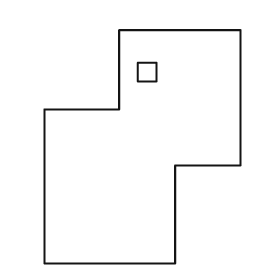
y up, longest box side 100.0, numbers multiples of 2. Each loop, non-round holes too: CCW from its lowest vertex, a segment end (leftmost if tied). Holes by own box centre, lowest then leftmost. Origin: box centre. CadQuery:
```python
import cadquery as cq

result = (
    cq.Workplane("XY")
    .moveTo(-42.0, -50.0)
    .lineTo(14.0, -50.0)
    .lineTo(14.0, -8.0)
    .lineTo(42.0, -8.0)
    .lineTo(42.0, 50.0)
    .lineTo(-10.0, 50.0)
    .lineTo(-10.0, 16.0)
    .lineTo(-42.0, 16.0)
    .close()
    .moveTo(-2.0, 28.0)
    .lineTo(6.0, 28.0)
    .lineTo(6.0, 36.0)
    .lineTo(-2.0, 36.0)
    .close()
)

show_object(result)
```